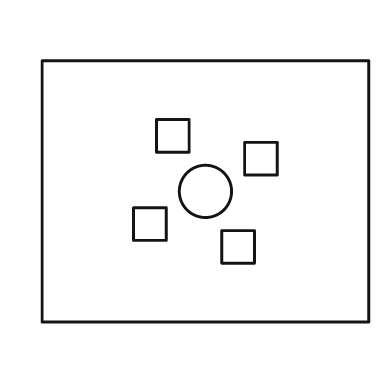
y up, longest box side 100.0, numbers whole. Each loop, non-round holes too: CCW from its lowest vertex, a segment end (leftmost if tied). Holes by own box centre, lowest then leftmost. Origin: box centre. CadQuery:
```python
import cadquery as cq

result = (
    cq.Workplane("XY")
    .moveTo(-50.0, -40.0)
    .lineTo(50.0, -40.0)
    .lineTo(50.0, 40.0)
    .lineTo(-50.0, 40.0)
    .close()
    .moveTo(5.0, -22.0)
    .lineTo(15.0, -22.0)
    .lineTo(15.0, -12.0)
    .lineTo(5.0, -12.0)
    .close()
    .moveTo(-22.0, -15.0)
    .lineTo(-12.0, -15.0)
    .lineTo(-12.0, -5.0)
    .lineTo(-22.0, -5.0)
    .close()
    .moveTo(0.0, 0.0)
    .circle(8.0)
    .moveTo(12.0, 5.0)
    .lineTo(22.0, 5.0)
    .lineTo(22.0, 15.0)
    .lineTo(12.0, 15.0)
    .close()
    .moveTo(-15.0, 12.0)
    .lineTo(-5.0, 12.0)
    .lineTo(-5.0, 22.0)
    .lineTo(-15.0, 22.0)
    .close()
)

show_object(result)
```